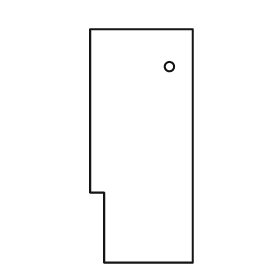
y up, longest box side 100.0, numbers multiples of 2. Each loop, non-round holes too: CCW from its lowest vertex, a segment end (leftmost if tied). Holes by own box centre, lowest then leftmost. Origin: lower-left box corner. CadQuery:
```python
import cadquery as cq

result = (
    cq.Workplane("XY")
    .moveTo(6.0, 0.0)
    .lineTo(44.0, 0.0)
    .lineTo(44.0, 100.0)
    .lineTo(0.0, 100.0)
    .lineTo(0.0, 30.0)
    .lineTo(6.0, 30.0)
    .close()
    .moveTo(34.0, 84.0)
    .circle(2.0)
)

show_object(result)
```